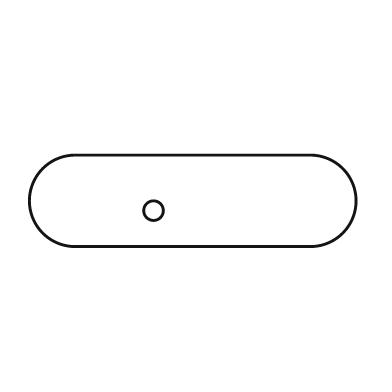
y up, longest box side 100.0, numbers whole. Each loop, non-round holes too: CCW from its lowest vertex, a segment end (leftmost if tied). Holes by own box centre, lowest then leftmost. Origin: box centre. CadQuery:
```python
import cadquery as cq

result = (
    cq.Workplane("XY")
    .moveTo(-36.0, -14.0)
    .lineTo(36.0, -14.0)
    .threePointArc((50.0, 0.0), (36.0, 14.0))
    .lineTo(-36.0, 14.0)
    .threePointArc((-50.0, 0.0), (-36.0, -14.0))
    .close()
    .moveTo(-12.0, -3.0)
    .circle(3.0)
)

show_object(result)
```